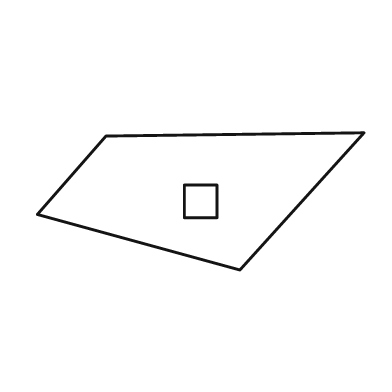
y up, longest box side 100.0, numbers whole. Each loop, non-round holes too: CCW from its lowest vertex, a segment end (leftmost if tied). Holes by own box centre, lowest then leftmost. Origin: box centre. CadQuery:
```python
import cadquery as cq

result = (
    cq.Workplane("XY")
    .moveTo(12.0, -21.0)
    .lineTo(50.0, 21.0)
    .lineTo(-29.0, 20.0)
    .lineTo(-50.0, -4.0)
    .close()
    .moveTo(-5.0, -5.0)
    .lineTo(5.0, -5.0)
    .lineTo(5.0, 5.0)
    .lineTo(-5.0, 5.0)
    .close()
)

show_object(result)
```